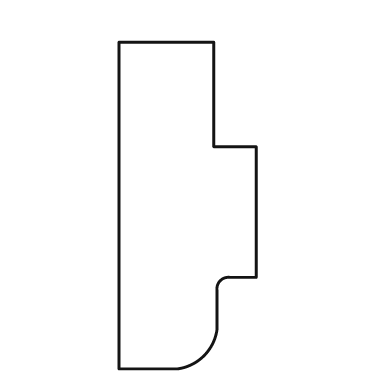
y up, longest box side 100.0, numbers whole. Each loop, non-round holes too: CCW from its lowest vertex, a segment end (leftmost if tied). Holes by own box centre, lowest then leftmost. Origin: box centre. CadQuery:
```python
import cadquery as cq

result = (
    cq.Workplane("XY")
    .moveTo(-21.0, -50.0)
    .lineTo(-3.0, -50.0)
    .threePointArc((5.0, -46.0), (9.0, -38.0))
    .lineTo(9.0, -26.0)
    .threePointArc((10.0, -23.0), (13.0, -22.0))
    .lineTo(21.0, -22.0)
    .lineTo(21.0, 18.0)
    .lineTo(8.0, 18.0)
    .lineTo(8.0, 50.0)
    .lineTo(-21.0, 50.0)
    .close()
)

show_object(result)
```